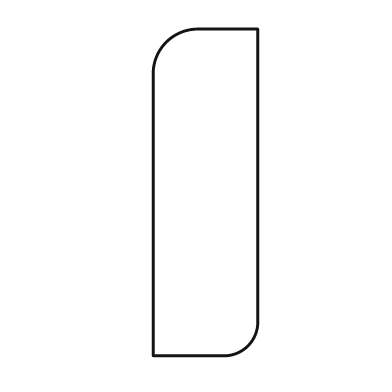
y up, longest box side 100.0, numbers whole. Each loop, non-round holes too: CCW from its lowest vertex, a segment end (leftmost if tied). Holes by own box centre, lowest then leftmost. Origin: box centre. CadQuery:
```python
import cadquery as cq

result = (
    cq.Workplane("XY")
    .moveTo(-16.0, -50.0)
    .lineTo(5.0, -50.0)
    .threePointArc((13.0, -47.0), (16.0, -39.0))
    .lineTo(16.0, 50.0)
    .lineTo(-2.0, 50.0)
    .threePointArc((-12.0, 46.0), (-16.0, 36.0))
    .close()
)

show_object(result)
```